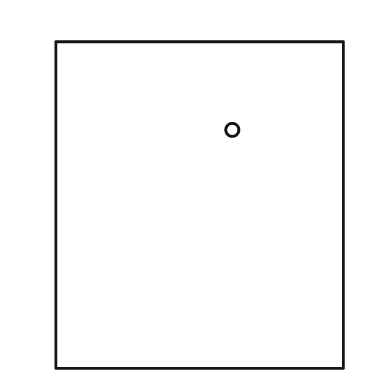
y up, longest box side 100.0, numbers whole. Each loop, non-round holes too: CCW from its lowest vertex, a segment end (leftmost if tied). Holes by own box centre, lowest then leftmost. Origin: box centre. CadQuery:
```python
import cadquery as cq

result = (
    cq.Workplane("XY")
    .moveTo(-44.0, -50.0)
    .lineTo(44.0, -50.0)
    .lineTo(44.0, 50.0)
    .lineTo(-44.0, 50.0)
    .close()
    .moveTo(10.0, 23.0)
    .circle(2.0)
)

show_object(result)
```